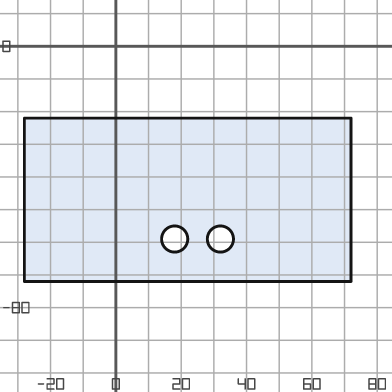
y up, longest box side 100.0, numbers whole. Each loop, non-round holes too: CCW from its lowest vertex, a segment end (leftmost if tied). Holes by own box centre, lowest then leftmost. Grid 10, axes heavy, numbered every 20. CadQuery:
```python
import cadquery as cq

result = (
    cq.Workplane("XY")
    .moveTo(-28.0, -72.0)
    .lineTo(72.0, -72.0)
    .lineTo(72.0, -22.0)
    .lineTo(-28.0, -22.0)
    .close()
    .moveTo(18.0, -59.0)
    .circle(4.0)
    .moveTo(32.0, -59.0)
    .circle(4.0)
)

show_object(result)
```